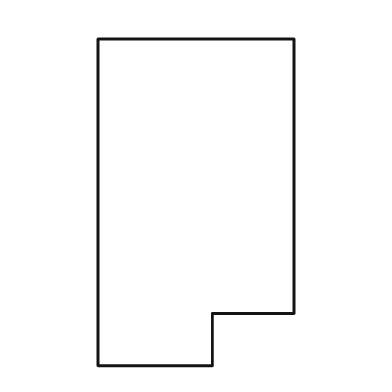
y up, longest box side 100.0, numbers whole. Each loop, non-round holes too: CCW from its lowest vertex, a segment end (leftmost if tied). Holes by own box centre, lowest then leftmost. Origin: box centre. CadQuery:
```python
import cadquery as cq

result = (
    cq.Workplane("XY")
    .moveTo(-30.0, -50.0)
    .lineTo(5.0, -50.0)
    .lineTo(5.0, -34.0)
    .lineTo(30.0, -34.0)
    .lineTo(30.0, 50.0)
    .lineTo(-30.0, 50.0)
    .close()
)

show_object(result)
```